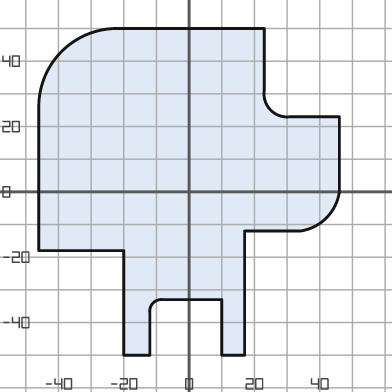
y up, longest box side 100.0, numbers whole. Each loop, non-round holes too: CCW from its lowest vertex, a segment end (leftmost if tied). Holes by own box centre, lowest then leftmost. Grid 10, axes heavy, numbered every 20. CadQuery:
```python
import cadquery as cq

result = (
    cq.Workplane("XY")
    .moveTo(-20.0, -50.0)
    .lineTo(-12.0, -50.0)
    .lineTo(-12.0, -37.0)
    .threePointArc((-11.0, -34.0), (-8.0, -33.0))
    .lineTo(10.0, -33.0)
    .lineTo(10.0, -50.0)
    .lineTo(17.0, -50.0)
    .lineTo(17.0, -12.0)
    .lineTo(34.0, -12.0)
    .threePointArc((42.0, -8.0), (46.0, 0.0))
    .lineTo(46.0, 23.0)
    .lineTo(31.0, 23.0)
    .threePointArc((25.0, 25.0), (23.0, 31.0))
    .lineTo(23.0, 50.0)
    .lineTo(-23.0, 50.0)
    .threePointArc((-39.0, 43.0), (-46.0, 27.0))
    .lineTo(-46.0, -18.0)
    .lineTo(-20.0, -18.0)
    .close()
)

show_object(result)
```